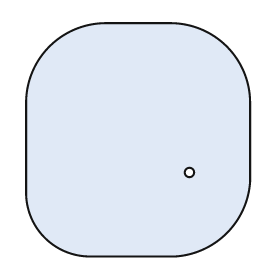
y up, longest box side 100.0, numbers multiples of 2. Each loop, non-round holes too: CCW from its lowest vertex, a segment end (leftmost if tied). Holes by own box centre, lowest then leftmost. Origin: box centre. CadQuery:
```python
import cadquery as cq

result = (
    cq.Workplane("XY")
    .moveTo(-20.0, -50.0)
    .lineTo(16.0, -50.0)
    .threePointArc((38.0, -40.0), (48.0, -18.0))
    .lineTo(48.0, 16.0)
    .threePointArc((38.0, 40.0), (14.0, 50.0))
    .lineTo(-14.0, 50.0)
    .threePointArc((-38.0, 40.0), (-48.0, 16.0))
    .lineTo(-48.0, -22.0)
    .threePointArc((-40.0, -42.0), (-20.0, -50.0))
    .close()
    .moveTo(22.0, -14.0)
    .circle(2.0)
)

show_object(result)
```